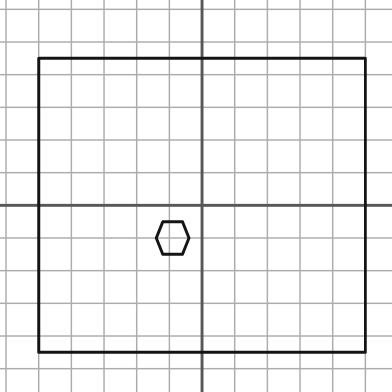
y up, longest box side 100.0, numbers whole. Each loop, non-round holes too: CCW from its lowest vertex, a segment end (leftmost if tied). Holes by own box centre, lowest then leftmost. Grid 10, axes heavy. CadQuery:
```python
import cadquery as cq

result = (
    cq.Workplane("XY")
    .moveTo(-50.0, -45.0)
    .lineTo(50.0, -45.0)
    .lineTo(50.0, 45.0)
    .lineTo(-50.0, 45.0)
    .close()
    .moveTo(-12.0, -15.0)
    .lineTo(-6.0, -15.0)
    .lineTo(-4.0, -10.0)
    .lineTo(-6.0, -5.0)
    .lineTo(-12.0, -5.0)
    .lineTo(-14.0, -10.0)
    .close()
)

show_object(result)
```